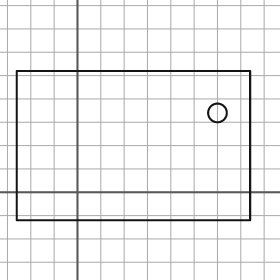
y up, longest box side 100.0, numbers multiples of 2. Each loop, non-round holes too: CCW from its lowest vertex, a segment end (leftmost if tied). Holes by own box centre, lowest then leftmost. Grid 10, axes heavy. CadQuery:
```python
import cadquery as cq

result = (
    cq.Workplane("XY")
    .moveTo(-26.0, -12.0)
    .lineTo(74.0, -12.0)
    .lineTo(74.0, 52.0)
    .lineTo(-26.0, 52.0)
    .close()
    .moveTo(60.0, 34.0)
    .circle(4.0)
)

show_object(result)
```